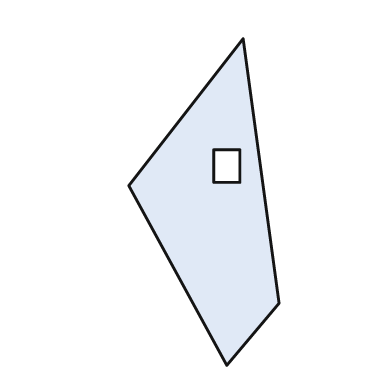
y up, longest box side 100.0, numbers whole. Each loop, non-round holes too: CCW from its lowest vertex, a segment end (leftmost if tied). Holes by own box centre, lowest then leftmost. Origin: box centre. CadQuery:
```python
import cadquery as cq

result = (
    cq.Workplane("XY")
    .moveTo(7.0, -50.0)
    .lineTo(23.0, -31.0)
    .lineTo(12.0, 50.0)
    .lineTo(-23.0, 5.0)
    .close()
    .moveTo(3.0, 6.0)
    .lineTo(11.0, 6.0)
    .lineTo(11.0, 16.0)
    .lineTo(3.0, 16.0)
    .close()
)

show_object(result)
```